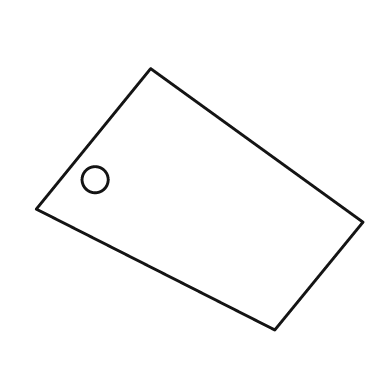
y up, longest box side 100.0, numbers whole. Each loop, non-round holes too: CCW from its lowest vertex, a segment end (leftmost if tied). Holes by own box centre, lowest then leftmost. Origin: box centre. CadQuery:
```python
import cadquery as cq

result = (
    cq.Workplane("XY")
    .moveTo(23.0, -40.0)
    .lineTo(50.0, -7.0)
    .lineTo(-15.0, 40.0)
    .lineTo(-50.0, -3.0)
    .close()
    .moveTo(-32.0, 6.0)
    .circle(4.0)
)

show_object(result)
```